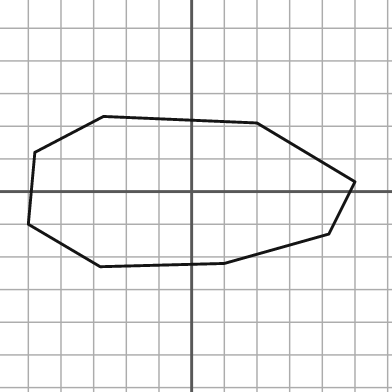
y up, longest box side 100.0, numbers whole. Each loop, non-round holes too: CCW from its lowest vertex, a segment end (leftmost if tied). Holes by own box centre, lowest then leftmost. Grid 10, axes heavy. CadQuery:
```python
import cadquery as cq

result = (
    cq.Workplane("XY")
    .moveTo(-28.0, -23.0)
    .lineTo(10.0, -22.0)
    .lineTo(42.0, -13.0)
    .lineTo(50.0, 3.0)
    .lineTo(20.0, 21.0)
    .lineTo(-27.0, 23.0)
    .lineTo(-48.0, 12.0)
    .lineTo(-50.0, -10.0)
    .close()
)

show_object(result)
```